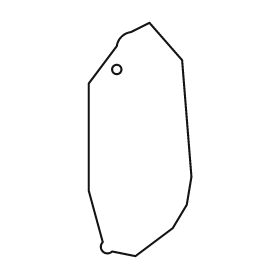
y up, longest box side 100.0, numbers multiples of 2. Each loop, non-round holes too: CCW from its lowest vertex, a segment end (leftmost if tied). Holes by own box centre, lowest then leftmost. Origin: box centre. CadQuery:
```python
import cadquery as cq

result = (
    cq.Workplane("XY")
    .moveTo(-2.0, -50.0)
    .lineTo(14.0, -38.0)
    .lineTo(20.0, -28.0)
    .lineTo(22.0, -16.0)
    .lineTo(18.0, 34.0)
    .lineTo(4.0, 50.0)
    .lineTo(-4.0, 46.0)
    .threePointArc((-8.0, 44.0), (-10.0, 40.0))
    .lineTo(-22.0, 24.0)
    .lineTo(-22.0, -22.0)
    .lineTo(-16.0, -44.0)
    .threePointArc((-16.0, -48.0), (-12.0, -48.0))
    .close()
    .moveTo(-10.0, 30.0)
    .circle(2.0)
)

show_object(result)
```